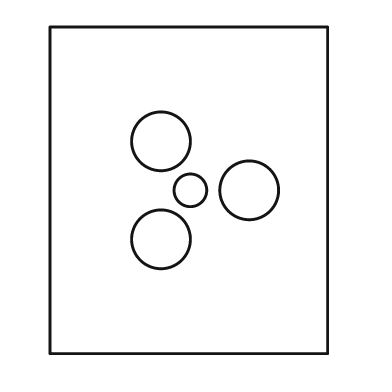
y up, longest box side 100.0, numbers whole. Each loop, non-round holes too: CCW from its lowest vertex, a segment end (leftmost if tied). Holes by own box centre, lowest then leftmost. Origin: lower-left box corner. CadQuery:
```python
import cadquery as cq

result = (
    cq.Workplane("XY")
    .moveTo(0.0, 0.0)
    .lineTo(85.0, 0.0)
    .lineTo(85.0, 100.0)
    .lineTo(0.0, 100.0)
    .close()
    .moveTo(34.0, 35.0)
    .circle(9.0)
    .moveTo(43.0, 50.0)
    .circle(5.0)
    .moveTo(61.0, 50.0)
    .circle(9.0)
    .moveTo(34.0, 65.0)
    .circle(9.0)
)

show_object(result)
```